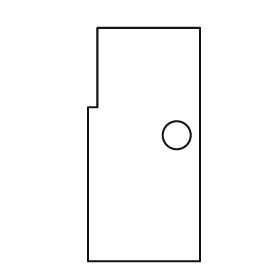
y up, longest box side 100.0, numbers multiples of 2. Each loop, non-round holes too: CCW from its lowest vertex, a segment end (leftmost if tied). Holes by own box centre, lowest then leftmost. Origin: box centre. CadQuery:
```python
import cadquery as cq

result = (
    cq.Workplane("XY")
    .moveTo(-24.0, -50.0)
    .lineTo(24.0, -50.0)
    .lineTo(24.0, 50.0)
    .lineTo(-20.0, 50.0)
    .lineTo(-20.0, 16.0)
    .lineTo(-24.0, 16.0)
    .close()
    .moveTo(14.0, 4.0)
    .circle(6.0)
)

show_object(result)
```